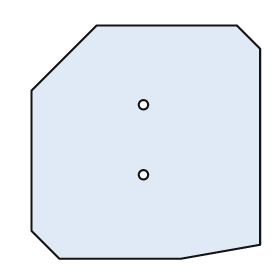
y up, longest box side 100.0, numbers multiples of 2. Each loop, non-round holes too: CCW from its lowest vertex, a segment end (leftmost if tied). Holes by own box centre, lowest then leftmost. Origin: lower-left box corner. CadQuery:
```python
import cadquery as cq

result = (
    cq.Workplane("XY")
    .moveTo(12.0, 0.0)
    .lineTo(64.0, 0.0)
    .lineTo(98.0, 6.0)
    .lineTo(98.0, 90.0)
    .lineTo(88.0, 100.0)
    .lineTo(28.0, 100.0)
    .lineTo(0.0, 72.0)
    .lineTo(0.0, 12.0)
    .close()
    .moveTo(48.0, 36.0)
    .circle(2.0)
    .moveTo(48.0, 66.0)
    .circle(2.0)
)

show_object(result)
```